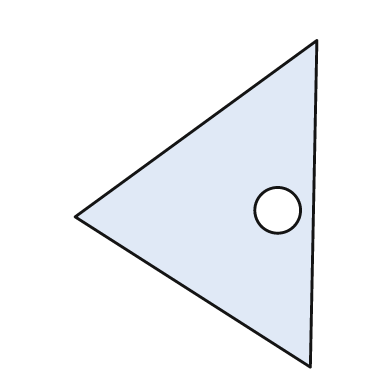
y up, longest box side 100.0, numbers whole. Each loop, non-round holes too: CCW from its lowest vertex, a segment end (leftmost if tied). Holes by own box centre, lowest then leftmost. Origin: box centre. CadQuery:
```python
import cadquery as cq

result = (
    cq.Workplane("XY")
    .moveTo(35.0, -50.0)
    .lineTo(37.0, 50.0)
    .lineTo(-37.0, -4.0)
    .close()
    .moveTo(25.0, -2.0)
    .circle(7.0)
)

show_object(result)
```